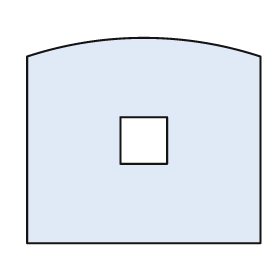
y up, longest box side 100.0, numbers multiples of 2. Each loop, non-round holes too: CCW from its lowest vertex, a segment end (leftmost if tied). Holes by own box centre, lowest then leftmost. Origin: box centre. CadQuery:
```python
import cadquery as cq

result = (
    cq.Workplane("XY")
    .moveTo(-50.0, -44.0)
    .lineTo(50.0, -44.0)
    .lineTo(50.0, 36.0)
    .threePointArc((0.0, 44.0), (-50.0, 36.0))
    .close()
    .moveTo(-10.0, -10.0)
    .lineTo(10.0, -10.0)
    .lineTo(10.0, 10.0)
    .lineTo(-10.0, 10.0)
    .close()
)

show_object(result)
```